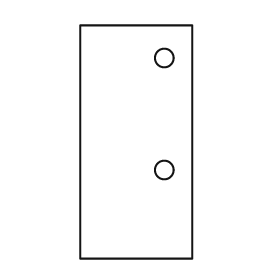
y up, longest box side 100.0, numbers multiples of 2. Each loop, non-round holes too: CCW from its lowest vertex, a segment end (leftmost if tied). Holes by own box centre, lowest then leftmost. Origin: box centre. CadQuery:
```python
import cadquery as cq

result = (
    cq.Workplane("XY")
    .moveTo(-24.0, -50.0)
    .lineTo(24.0, -50.0)
    .lineTo(24.0, 50.0)
    .lineTo(-24.0, 50.0)
    .close()
    .moveTo(12.0, -12.0)
    .circle(4.0)
    .moveTo(12.0, 36.0)
    .circle(4.0)
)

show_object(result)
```